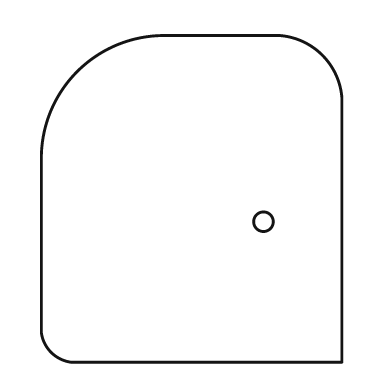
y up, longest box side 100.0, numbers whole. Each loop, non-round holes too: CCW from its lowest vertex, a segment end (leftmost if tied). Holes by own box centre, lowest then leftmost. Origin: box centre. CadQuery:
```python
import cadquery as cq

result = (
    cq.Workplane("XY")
    .moveTo(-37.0, -50.0)
    .lineTo(46.0, -50.0)
    .lineTo(46.0, 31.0)
    .threePointArc((40.0, 44.0), (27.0, 50.0))
    .lineTo(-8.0, 50.0)
    .threePointArc((-35.0, 39.0), (-46.0, 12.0))
    .lineTo(-46.0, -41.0)
    .threePointArc((-43.0, -47.0), (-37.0, -50.0))
    .close()
    .moveTo(22.0, -7.0)
    .circle(3.0)
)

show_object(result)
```